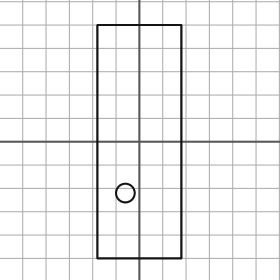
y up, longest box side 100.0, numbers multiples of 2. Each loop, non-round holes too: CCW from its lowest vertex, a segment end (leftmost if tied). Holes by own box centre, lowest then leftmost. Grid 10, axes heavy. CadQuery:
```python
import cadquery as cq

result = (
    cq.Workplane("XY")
    .moveTo(-18.0, -50.0)
    .lineTo(18.0, -50.0)
    .lineTo(18.0, 50.0)
    .lineTo(-18.0, 50.0)
    .close()
    .moveTo(-6.0, -22.0)
    .circle(4.0)
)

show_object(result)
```